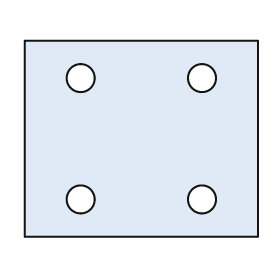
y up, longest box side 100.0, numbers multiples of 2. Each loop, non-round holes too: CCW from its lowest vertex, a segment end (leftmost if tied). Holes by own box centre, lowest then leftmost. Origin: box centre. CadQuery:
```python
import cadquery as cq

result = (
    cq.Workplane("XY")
    .moveTo(-50.0, -42.0)
    .lineTo(50.0, -42.0)
    .lineTo(50.0, 42.0)
    .lineTo(-50.0, 42.0)
    .close()
    .moveTo(-26.0, -26.0)
    .circle(6.0)
    .moveTo(26.0, -26.0)
    .circle(6.0)
    .moveTo(-26.0, 26.0)
    .circle(6.0)
    .moveTo(26.0, 26.0)
    .circle(6.0)
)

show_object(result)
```